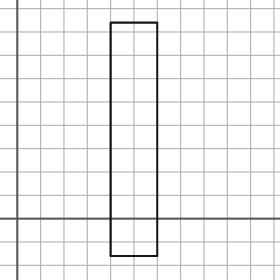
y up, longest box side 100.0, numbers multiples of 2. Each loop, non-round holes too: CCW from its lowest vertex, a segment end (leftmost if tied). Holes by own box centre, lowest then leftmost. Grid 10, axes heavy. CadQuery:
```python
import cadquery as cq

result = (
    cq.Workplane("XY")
    .moveTo(40.0, -16.0)
    .lineTo(60.0, -16.0)
    .lineTo(60.0, 84.0)
    .lineTo(40.0, 84.0)
    .close()
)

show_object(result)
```